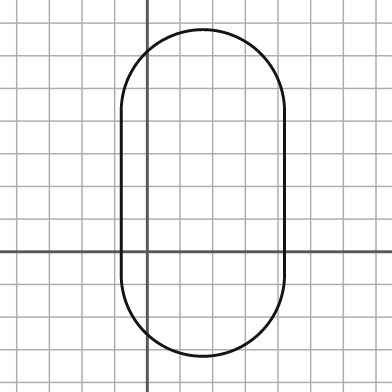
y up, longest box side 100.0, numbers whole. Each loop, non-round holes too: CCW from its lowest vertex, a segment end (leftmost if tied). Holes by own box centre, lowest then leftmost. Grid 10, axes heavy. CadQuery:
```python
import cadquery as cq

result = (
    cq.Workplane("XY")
    .moveTo(-8.0, -7.0)
    .threePointArc((17.0, -32.0), (42.0, -7.0))
    .lineTo(42.0, 43.0)
    .threePointArc((17.0, 68.0), (-8.0, 43.0))
    .close()
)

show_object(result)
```